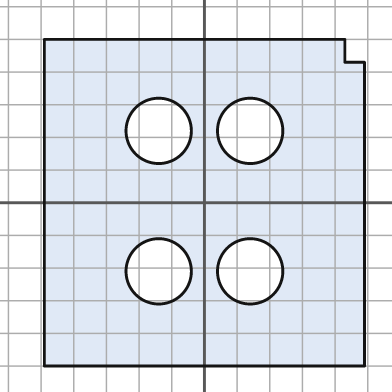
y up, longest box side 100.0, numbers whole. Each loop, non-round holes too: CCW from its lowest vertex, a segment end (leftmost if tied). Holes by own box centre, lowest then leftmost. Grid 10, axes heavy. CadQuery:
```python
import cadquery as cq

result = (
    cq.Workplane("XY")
    .moveTo(-49.0, -50.0)
    .lineTo(49.0, -50.0)
    .lineTo(49.0, 43.0)
    .lineTo(43.0, 43.0)
    .lineTo(43.0, 50.0)
    .lineTo(-49.0, 50.0)
    .close()
    .moveTo(-14.0, -21.0)
    .circle(10.0)
    .moveTo(14.0, -21.0)
    .circle(10.0)
    .moveTo(-14.0, 22.0)
    .circle(10.0)
    .moveTo(14.0, 22.0)
    .circle(10.0)
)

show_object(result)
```